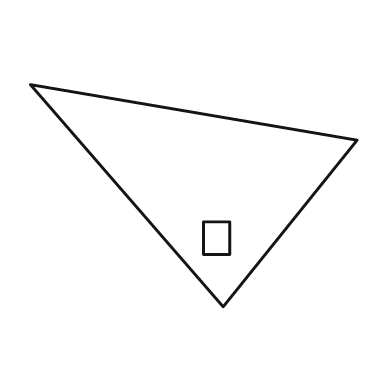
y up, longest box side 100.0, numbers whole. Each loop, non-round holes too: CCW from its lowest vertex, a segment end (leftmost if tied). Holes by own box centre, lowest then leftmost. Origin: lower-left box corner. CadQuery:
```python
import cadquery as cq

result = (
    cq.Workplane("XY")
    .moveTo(59.0, 0.0)
    .lineTo(100.0, 51.0)
    .lineTo(0.0, 68.0)
    .close()
    .moveTo(53.0, 16.0)
    .lineTo(61.0, 16.0)
    .lineTo(61.0, 26.0)
    .lineTo(53.0, 26.0)
    .close()
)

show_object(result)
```